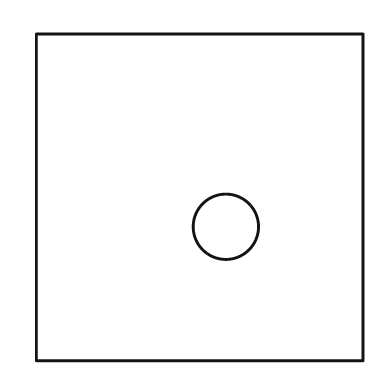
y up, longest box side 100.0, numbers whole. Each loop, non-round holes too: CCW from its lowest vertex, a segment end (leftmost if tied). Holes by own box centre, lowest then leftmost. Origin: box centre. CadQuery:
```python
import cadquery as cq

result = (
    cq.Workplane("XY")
    .moveTo(-50.0, -50.0)
    .lineTo(50.0, -50.0)
    .lineTo(50.0, 50.0)
    .lineTo(-50.0, 50.0)
    .close()
    .moveTo(8.0, -9.0)
    .circle(10.0)
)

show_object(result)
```